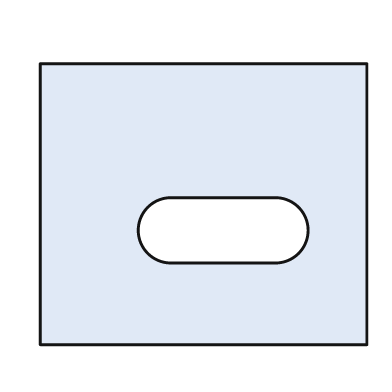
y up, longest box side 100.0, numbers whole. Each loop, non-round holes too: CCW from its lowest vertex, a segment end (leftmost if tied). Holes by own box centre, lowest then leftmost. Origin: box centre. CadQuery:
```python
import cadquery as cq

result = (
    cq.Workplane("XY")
    .moveTo(-50.0, -43.0)
    .lineTo(50.0, -43.0)
    .lineTo(50.0, 43.0)
    .lineTo(-50.0, 43.0)
    .close()
    .moveTo(-10.0, -18.0)
    .lineTo(22.0, -18.0)
    .threePointArc((32.0, -8.0), (22.0, 2.0))
    .lineTo(-10.0, 2.0)
    .threePointArc((-20.0, -8.0), (-10.0, -18.0))
    .close()
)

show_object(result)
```